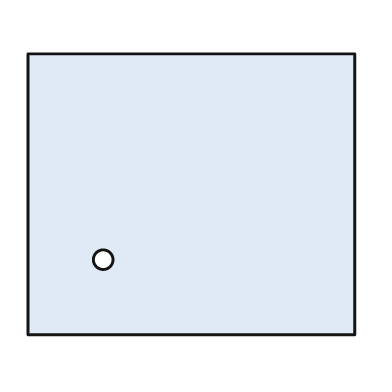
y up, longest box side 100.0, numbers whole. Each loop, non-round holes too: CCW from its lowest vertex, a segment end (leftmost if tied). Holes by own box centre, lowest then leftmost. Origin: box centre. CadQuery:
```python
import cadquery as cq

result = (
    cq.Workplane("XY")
    .moveTo(-50.0, -43.0)
    .lineTo(50.0, -43.0)
    .lineTo(50.0, 43.0)
    .lineTo(-50.0, 43.0)
    .close()
    .moveTo(-27.0, -20.0)
    .circle(3.0)
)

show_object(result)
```